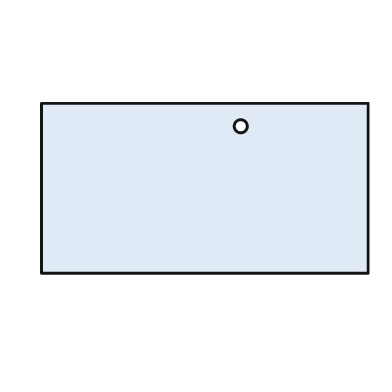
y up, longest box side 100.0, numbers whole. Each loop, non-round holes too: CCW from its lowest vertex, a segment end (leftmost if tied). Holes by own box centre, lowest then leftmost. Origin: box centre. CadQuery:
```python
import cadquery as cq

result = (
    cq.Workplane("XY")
    .moveTo(-50.0, -26.0)
    .lineTo(50.0, -26.0)
    .lineTo(50.0, 26.0)
    .lineTo(-50.0, 26.0)
    .close()
    .moveTo(11.0, 19.0)
    .circle(2.0)
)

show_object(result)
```